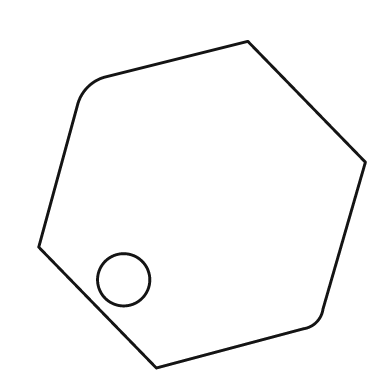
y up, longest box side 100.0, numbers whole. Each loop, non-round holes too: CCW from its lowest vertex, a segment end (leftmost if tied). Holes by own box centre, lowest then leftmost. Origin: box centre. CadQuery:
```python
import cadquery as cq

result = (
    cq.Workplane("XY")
    .moveTo(-14.0, -50.0)
    .lineTo(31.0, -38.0)
    .threePointArc((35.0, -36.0), (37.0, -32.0))
    .lineTo(50.0, 13.0)
    .lineTo(14.0, 50.0)
    .lineTo(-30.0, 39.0)
    .threePointArc((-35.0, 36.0), (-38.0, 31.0))
    .lineTo(-50.0, -13.0)
    .close()
    .moveTo(-24.0, -23.0)
    .circle(8.0)
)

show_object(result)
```